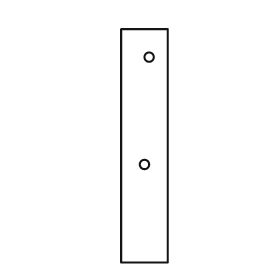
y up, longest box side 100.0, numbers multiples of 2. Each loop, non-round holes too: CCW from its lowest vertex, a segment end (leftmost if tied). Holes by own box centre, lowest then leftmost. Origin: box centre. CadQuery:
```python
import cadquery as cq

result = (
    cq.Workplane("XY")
    .moveTo(-10.0, -50.0)
    .lineTo(10.0, -50.0)
    .lineTo(10.0, 50.0)
    .lineTo(-10.0, 50.0)
    .close()
    .moveTo(0.0, -8.0)
    .circle(2.0)
    .moveTo(2.0, 38.0)
    .circle(2.0)
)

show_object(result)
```